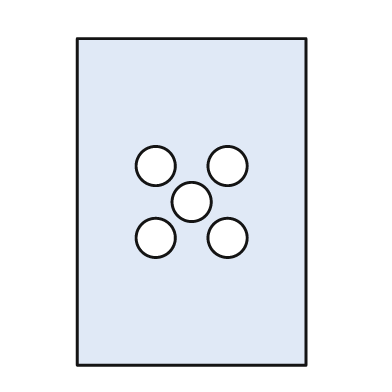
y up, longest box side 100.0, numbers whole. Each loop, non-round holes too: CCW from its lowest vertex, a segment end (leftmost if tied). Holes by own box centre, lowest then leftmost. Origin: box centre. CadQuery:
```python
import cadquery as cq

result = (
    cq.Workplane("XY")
    .moveTo(-35.0, -50.0)
    .lineTo(35.0, -50.0)
    .lineTo(35.0, 50.0)
    .lineTo(-35.0, 50.0)
    .close()
    .moveTo(-11.0, -11.0)
    .circle(6.0)
    .moveTo(11.0, -11.0)
    .circle(6.0)
    .moveTo(0.0, 0.0)
    .circle(6.0)
    .moveTo(-11.0, 11.0)
    .circle(6.0)
    .moveTo(11.0, 11.0)
    .circle(6.0)
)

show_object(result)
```